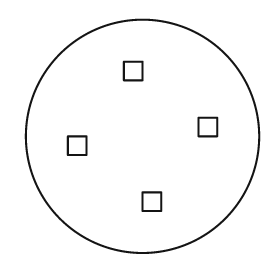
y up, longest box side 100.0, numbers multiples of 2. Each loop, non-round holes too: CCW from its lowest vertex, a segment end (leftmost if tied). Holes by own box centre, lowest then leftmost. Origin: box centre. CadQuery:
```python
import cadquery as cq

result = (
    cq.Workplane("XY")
    .moveTo(0.0, 0.0)
    .circle(50.0)
    .moveTo(0.0, -32.0)
    .lineTo(8.0, -32.0)
    .lineTo(8.0, -24.0)
    .lineTo(0.0, -24.0)
    .close()
    .moveTo(-32.0, -8.0)
    .lineTo(-24.0, -8.0)
    .lineTo(-24.0, 0.0)
    .lineTo(-32.0, 0.0)
    .close()
    .moveTo(24.0, 0.0)
    .lineTo(32.0, 0.0)
    .lineTo(32.0, 8.0)
    .lineTo(24.0, 8.0)
    .close()
    .moveTo(-8.0, 24.0)
    .lineTo(0.0, 24.0)
    .lineTo(0.0, 32.0)
    .lineTo(-8.0, 32.0)
    .close()
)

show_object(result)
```